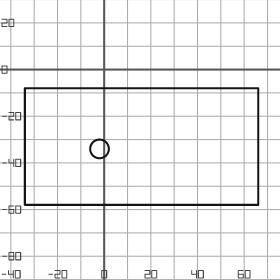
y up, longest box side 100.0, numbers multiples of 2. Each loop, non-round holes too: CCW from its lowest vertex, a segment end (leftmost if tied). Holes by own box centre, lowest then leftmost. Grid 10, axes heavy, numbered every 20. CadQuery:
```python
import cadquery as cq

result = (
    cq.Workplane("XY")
    .moveTo(-34.0, -58.0)
    .lineTo(66.0, -58.0)
    .lineTo(66.0, -8.0)
    .lineTo(-34.0, -8.0)
    .close()
    .moveTo(-2.0, -34.0)
    .circle(4.0)
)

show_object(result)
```